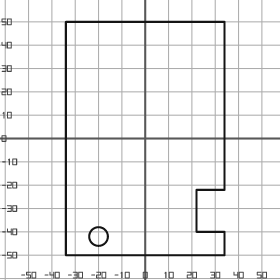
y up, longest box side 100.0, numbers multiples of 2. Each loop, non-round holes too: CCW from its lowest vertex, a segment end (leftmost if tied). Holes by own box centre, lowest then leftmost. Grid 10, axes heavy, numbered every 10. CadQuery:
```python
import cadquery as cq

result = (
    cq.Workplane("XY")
    .moveTo(-34.0, -50.0)
    .lineTo(34.0, -50.0)
    .lineTo(34.0, -40.0)
    .lineTo(22.0, -40.0)
    .lineTo(22.0, -22.0)
    .lineTo(34.0, -22.0)
    .lineTo(34.0, 50.0)
    .lineTo(-34.0, 50.0)
    .close()
    .moveTo(-20.0, -42.0)
    .circle(4.0)
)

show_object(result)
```